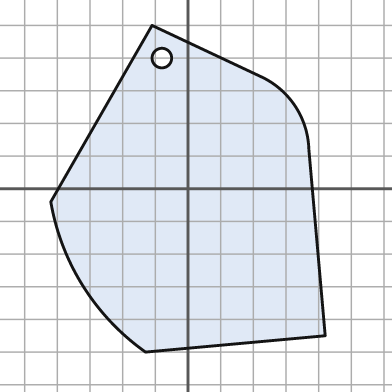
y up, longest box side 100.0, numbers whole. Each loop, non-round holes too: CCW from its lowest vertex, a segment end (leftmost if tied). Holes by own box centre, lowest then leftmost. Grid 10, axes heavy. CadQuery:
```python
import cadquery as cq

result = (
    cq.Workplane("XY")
    .moveTo(-13.0, -50.0)
    .lineTo(42.0, -45.0)
    .lineTo(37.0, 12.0)
    .threePointArc((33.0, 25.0), (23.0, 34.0))
    .lineTo(-11.0, 50.0)
    .lineTo(-42.0, -4.0)
    .threePointArc((-32.0, -30.0), (-13.0, -50.0))
    .close()
    .moveTo(-8.0, 40.0)
    .circle(3.0)
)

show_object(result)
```